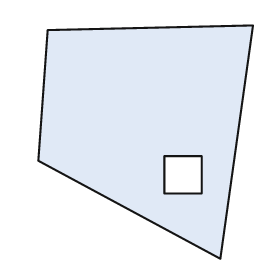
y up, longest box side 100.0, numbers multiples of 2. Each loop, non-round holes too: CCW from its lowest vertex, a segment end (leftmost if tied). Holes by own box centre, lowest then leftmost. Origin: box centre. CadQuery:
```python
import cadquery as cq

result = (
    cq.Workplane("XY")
    .moveTo(32.0, -50.0)
    .lineTo(46.0, 50.0)
    .lineTo(-42.0, 48.0)
    .lineTo(-46.0, -8.0)
    .close()
    .moveTo(8.0, -22.0)
    .lineTo(24.0, -22.0)
    .lineTo(24.0, -6.0)
    .lineTo(8.0, -6.0)
    .close()
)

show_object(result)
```